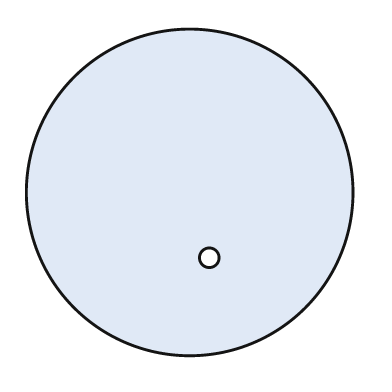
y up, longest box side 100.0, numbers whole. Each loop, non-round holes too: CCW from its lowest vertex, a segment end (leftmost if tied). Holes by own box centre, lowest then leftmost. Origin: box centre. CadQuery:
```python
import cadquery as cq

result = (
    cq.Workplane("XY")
    .moveTo(0.0, 0.0)
    .circle(50.0)
    .moveTo(6.0, -20.0)
    .circle(3.0)
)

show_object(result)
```